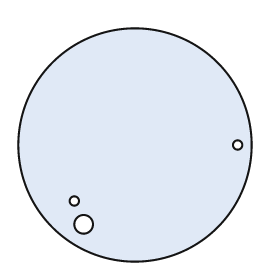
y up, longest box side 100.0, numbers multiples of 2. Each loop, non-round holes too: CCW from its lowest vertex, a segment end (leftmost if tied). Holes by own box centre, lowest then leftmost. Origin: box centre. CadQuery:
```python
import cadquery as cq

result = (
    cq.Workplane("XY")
    .moveTo(0.0, 0.0)
    .circle(50.0)
    .moveTo(-22.0, -34.0)
    .circle(4.0)
    .moveTo(-26.0, -24.0)
    .circle(2.0)
    .moveTo(44.0, 0.0)
    .circle(2.0)
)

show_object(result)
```